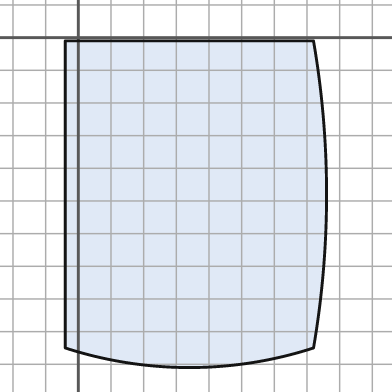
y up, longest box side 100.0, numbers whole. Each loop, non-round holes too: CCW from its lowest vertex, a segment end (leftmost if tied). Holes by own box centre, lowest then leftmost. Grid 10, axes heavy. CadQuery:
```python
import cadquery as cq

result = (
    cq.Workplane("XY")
    .moveTo(-4.0, -95.0)
    .threePointArc((34.0, -101.0), (72.0, -95.0))
    .threePointArc((76.0, -48.0), (72.0, -1.0))
    .lineTo(-4.0, -1.0)
    .close()
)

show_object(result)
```